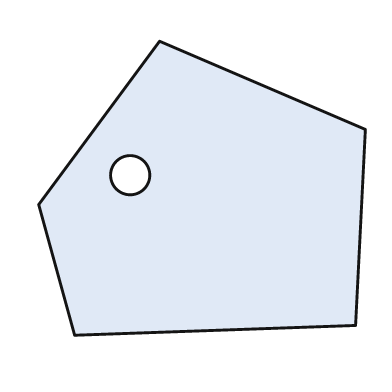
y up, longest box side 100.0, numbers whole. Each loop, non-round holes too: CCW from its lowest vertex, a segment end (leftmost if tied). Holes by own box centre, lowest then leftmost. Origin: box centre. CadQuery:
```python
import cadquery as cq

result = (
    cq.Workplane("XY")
    .moveTo(-39.0, -45.0)
    .lineTo(47.0, -42.0)
    .lineTo(50.0, 18.0)
    .lineTo(-13.0, 45.0)
    .lineTo(-50.0, -5.0)
    .close()
    .moveTo(-22.0, 4.0)
    .circle(6.0)
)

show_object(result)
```